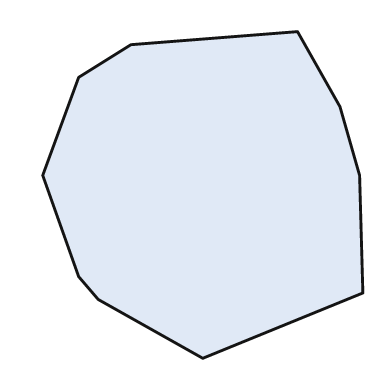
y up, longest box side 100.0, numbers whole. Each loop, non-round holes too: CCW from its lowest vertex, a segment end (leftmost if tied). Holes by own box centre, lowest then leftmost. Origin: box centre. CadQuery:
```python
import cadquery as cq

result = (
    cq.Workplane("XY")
    .moveTo(0.0, -50.0)
    .lineTo(49.0, -30.0)
    .lineTo(48.0, 6.0)
    .lineTo(42.0, 27.0)
    .lineTo(29.0, 50.0)
    .lineTo(-22.0, 46.0)
    .lineTo(-38.0, 36.0)
    .lineTo(-49.0, 6.0)
    .lineTo(-38.0, -25.0)
    .lineTo(-32.0, -32.0)
    .close()
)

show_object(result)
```